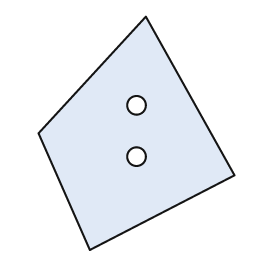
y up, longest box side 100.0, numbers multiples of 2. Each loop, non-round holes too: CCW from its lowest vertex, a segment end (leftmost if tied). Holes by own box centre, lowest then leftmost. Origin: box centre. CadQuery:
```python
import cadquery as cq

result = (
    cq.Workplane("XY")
    .moveTo(-20.0, -50.0)
    .lineTo(42.0, -18.0)
    .lineTo(4.0, 50.0)
    .lineTo(-42.0, 0.0)
    .close()
    .moveTo(0.0, -10.0)
    .circle(4.0)
    .moveTo(0.0, 12.0)
    .circle(4.0)
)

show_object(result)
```